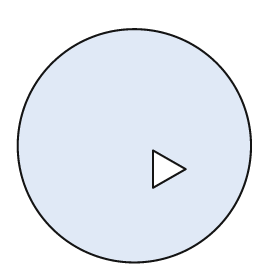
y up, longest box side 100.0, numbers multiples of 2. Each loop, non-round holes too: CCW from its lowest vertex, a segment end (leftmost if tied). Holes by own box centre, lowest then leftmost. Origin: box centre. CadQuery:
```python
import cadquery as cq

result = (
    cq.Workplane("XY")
    .moveTo(0.0, 0.0)
    .circle(50.0)
    .moveTo(8.0, -18.0)
    .lineTo(22.0, -10.0)
    .lineTo(8.0, -2.0)
    .close()
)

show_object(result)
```